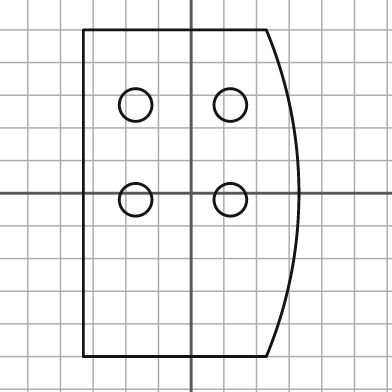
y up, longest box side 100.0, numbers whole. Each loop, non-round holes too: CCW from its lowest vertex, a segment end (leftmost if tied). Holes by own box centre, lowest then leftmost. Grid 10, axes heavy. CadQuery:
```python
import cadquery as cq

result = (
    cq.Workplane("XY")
    .moveTo(-33.0, -50.0)
    .lineTo(23.0, -50.0)
    .threePointArc((33.0, 0.0), (23.0, 50.0))
    .lineTo(-33.0, 50.0)
    .close()
    .moveTo(-17.0, -2.0)
    .circle(5.0)
    .moveTo(12.0, -2.0)
    .circle(5.0)
    .moveTo(-17.0, 27.0)
    .circle(5.0)
    .moveTo(12.0, 27.0)
    .circle(5.0)
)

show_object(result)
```